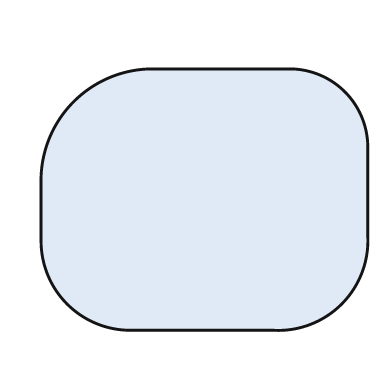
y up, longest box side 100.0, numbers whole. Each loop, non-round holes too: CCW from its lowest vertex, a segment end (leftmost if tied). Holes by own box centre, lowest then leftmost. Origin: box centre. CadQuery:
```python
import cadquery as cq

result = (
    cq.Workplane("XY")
    .moveTo(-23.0, -40.0)
    .lineTo(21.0, -40.0)
    .threePointArc((42.0, -32.0), (50.0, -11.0))
    .lineTo(50.0, 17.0)
    .threePointArc((43.0, 33.0), (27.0, 40.0))
    .lineTo(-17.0, 40.0)
    .threePointArc((-40.0, 30.0), (-50.0, 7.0))
    .lineTo(-50.0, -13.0)
    .threePointArc((-42.0, -32.0), (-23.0, -40.0))
    .close()
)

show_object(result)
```